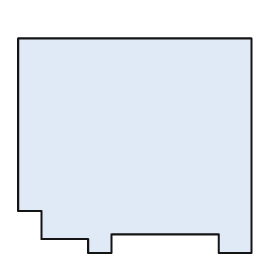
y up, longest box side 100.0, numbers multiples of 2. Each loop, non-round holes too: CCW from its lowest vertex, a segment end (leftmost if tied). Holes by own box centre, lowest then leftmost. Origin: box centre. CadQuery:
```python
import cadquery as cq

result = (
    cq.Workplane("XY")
    .moveTo(-20.0, -46.0)
    .lineTo(-10.0, -46.0)
    .lineTo(-10.0, -38.0)
    .lineTo(36.0, -38.0)
    .lineTo(36.0, -46.0)
    .lineTo(50.0, -46.0)
    .lineTo(50.0, 46.0)
    .lineTo(-50.0, 46.0)
    .lineTo(-50.0, -28.0)
    .lineTo(-40.0, -28.0)
    .lineTo(-40.0, -40.0)
    .lineTo(-20.0, -40.0)
    .close()
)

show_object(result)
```